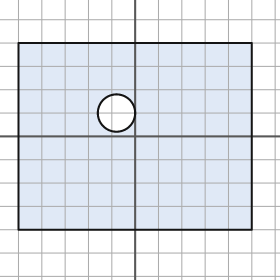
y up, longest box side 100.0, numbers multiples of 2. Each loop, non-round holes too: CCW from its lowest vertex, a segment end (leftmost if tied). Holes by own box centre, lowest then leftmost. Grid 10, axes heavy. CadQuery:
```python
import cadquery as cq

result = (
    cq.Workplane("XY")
    .moveTo(-50.0, -40.0)
    .lineTo(50.0, -40.0)
    .lineTo(50.0, 40.0)
    .lineTo(-50.0, 40.0)
    .close()
    .moveTo(-8.0, 10.0)
    .circle(8.0)
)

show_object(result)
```